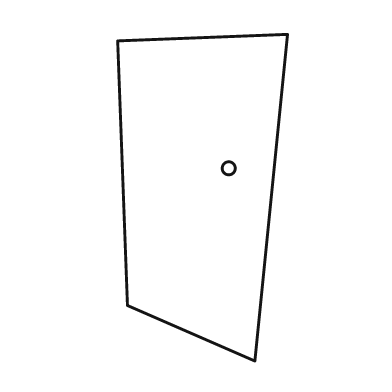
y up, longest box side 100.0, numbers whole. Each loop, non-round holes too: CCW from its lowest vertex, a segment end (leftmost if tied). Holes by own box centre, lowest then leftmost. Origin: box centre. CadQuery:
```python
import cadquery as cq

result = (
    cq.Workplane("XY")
    .moveTo(16.0, -50.0)
    .lineTo(26.0, 50.0)
    .lineTo(-26.0, 48.0)
    .lineTo(-23.0, -33.0)
    .close()
    .moveTo(8.0, 9.0)
    .circle(2.0)
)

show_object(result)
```